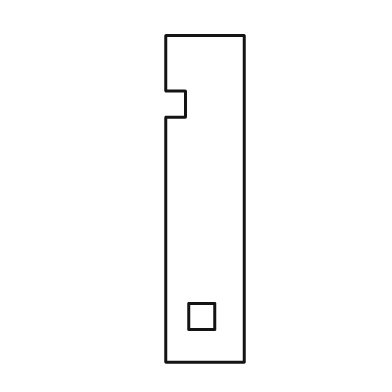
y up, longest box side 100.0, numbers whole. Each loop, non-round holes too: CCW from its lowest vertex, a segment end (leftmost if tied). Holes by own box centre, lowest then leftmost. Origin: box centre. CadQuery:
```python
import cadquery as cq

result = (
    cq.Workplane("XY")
    .moveTo(-12.0, -50.0)
    .lineTo(12.0, -50.0)
    .lineTo(12.0, 50.0)
    .lineTo(-12.0, 50.0)
    .lineTo(-12.0, 33.0)
    .lineTo(-6.0, 33.0)
    .lineTo(-6.0, 25.0)
    .lineTo(-12.0, 25.0)
    .close()
    .moveTo(-5.0, -40.0)
    .lineTo(3.0, -40.0)
    .lineTo(3.0, -32.0)
    .lineTo(-5.0, -32.0)
    .close()
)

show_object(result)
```